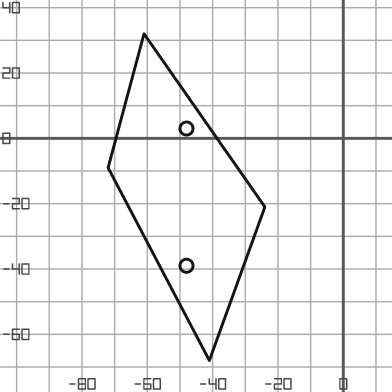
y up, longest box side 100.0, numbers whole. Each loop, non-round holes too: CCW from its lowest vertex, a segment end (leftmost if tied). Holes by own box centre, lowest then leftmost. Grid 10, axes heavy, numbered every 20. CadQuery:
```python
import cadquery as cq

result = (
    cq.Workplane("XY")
    .moveTo(-41.0, -68.0)
    .lineTo(-24.0, -21.0)
    .lineTo(-61.0, 32.0)
    .lineTo(-72.0, -9.0)
    .close()
    .moveTo(-48.0, -39.0)
    .circle(2.0)
    .moveTo(-48.0, 3.0)
    .circle(2.0)
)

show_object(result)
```